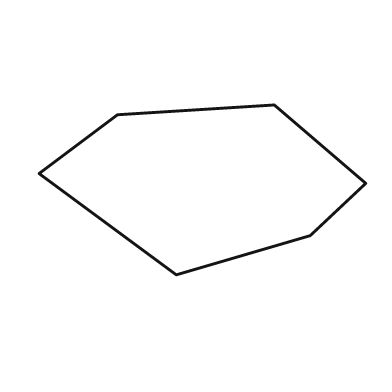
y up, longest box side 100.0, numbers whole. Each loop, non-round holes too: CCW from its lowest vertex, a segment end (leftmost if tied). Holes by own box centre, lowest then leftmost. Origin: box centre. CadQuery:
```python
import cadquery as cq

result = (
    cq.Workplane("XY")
    .moveTo(-8.0, -26.0)
    .lineTo(33.0, -14.0)
    .lineTo(50.0, 2.0)
    .lineTo(22.0, 26.0)
    .lineTo(-26.0, 23.0)
    .lineTo(-50.0, 5.0)
    .close()
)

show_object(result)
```